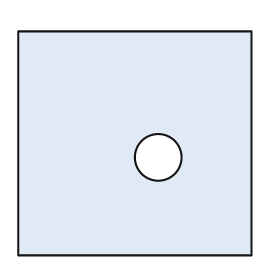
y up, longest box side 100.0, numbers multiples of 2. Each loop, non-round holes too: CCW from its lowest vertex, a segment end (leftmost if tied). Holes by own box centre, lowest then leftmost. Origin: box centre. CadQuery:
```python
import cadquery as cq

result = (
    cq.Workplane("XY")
    .moveTo(-50.0, -48.0)
    .lineTo(50.0, -48.0)
    .lineTo(50.0, 48.0)
    .lineTo(-50.0, 48.0)
    .close()
    .moveTo(10.0, -6.0)
    .circle(10.0)
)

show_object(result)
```